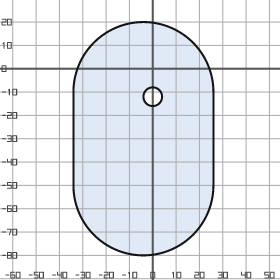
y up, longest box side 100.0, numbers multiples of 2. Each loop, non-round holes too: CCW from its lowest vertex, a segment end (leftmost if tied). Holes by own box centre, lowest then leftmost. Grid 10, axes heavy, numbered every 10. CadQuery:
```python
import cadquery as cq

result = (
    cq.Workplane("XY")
    .moveTo(-34.0, -50.0)
    .threePointArc((-4.0, -80.0), (26.0, -50.0))
    .lineTo(26.0, -10.0)
    .threePointArc((-4.0, 20.0), (-34.0, -10.0))
    .close()
    .moveTo(0.0, -12.0)
    .circle(4.0)
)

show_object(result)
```